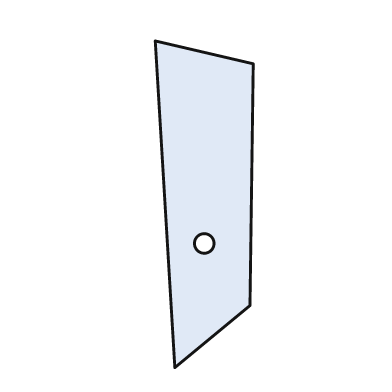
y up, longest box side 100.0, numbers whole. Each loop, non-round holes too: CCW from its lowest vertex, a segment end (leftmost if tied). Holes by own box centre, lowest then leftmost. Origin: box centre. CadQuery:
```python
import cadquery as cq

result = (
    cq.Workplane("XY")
    .moveTo(-9.0, -50.0)
    .lineTo(14.0, -31.0)
    .lineTo(15.0, 43.0)
    .lineTo(-15.0, 50.0)
    .close()
    .moveTo(0.0, -12.0)
    .circle(3.0)
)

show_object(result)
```